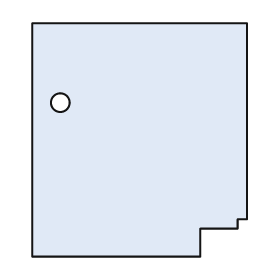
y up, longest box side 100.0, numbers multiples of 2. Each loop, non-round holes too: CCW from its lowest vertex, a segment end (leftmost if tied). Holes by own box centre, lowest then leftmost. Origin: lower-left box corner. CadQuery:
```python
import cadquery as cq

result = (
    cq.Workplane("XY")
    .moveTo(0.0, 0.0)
    .lineTo(72.0, 0.0)
    .lineTo(72.0, 12.0)
    .lineTo(88.0, 12.0)
    .lineTo(88.0, 16.0)
    .lineTo(92.0, 16.0)
    .lineTo(92.0, 100.0)
    .lineTo(0.0, 100.0)
    .close()
    .moveTo(12.0, 66.0)
    .circle(4.0)
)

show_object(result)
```